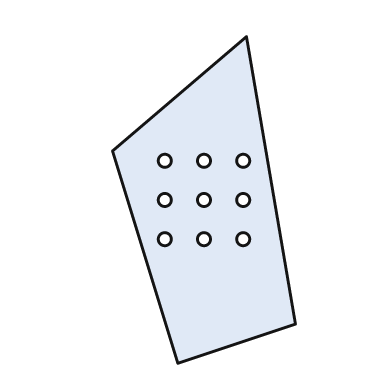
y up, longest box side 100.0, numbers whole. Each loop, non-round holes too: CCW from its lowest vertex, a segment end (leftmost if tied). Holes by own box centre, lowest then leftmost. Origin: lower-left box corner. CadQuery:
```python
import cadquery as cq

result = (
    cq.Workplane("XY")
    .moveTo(20.0, 0.0)
    .lineTo(56.0, 12.0)
    .lineTo(41.0, 100.0)
    .lineTo(0.0, 65.0)
    .close()
    .moveTo(16.0, 38.0)
    .circle(2.0)
    .moveTo(28.0, 38.0)
    .circle(2.0)
    .moveTo(40.0, 38.0)
    .circle(2.0)
    .moveTo(16.0, 50.0)
    .circle(2.0)
    .moveTo(28.0, 50.0)
    .circle(2.0)
    .moveTo(40.0, 50.0)
    .circle(2.0)
    .moveTo(16.0, 62.0)
    .circle(2.0)
    .moveTo(28.0, 62.0)
    .circle(2.0)
    .moveTo(40.0, 62.0)
    .circle(2.0)
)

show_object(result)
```